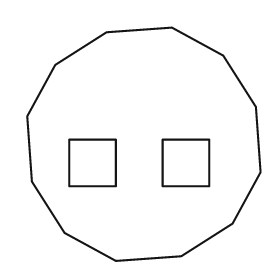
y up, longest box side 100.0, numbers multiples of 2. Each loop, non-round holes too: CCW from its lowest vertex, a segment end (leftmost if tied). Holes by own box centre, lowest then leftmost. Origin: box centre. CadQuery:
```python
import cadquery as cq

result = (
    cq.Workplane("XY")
    .moveTo(-12.0, -50.0)
    .lineTo(16.0, -48.0)
    .lineTo(38.0, -34.0)
    .lineTo(50.0, -12.0)
    .lineTo(48.0, 16.0)
    .lineTo(34.0, 38.0)
    .lineTo(12.0, 50.0)
    .lineTo(-16.0, 48.0)
    .lineTo(-38.0, 34.0)
    .lineTo(-50.0, 12.0)
    .lineTo(-48.0, -16.0)
    .lineTo(-34.0, -38.0)
    .close()
    .moveTo(-32.0, -18.0)
    .lineTo(-12.0, -18.0)
    .lineTo(-12.0, 2.0)
    .lineTo(-32.0, 2.0)
    .close()
    .moveTo(8.0, -18.0)
    .lineTo(28.0, -18.0)
    .lineTo(28.0, 2.0)
    .lineTo(8.0, 2.0)
    .close()
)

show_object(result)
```